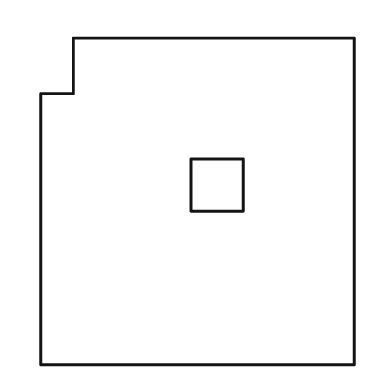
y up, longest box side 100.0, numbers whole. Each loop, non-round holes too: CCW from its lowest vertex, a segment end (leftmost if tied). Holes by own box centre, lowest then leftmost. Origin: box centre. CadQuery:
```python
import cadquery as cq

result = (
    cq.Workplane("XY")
    .moveTo(-48.0, -50.0)
    .lineTo(48.0, -50.0)
    .lineTo(48.0, 50.0)
    .lineTo(-38.0, 50.0)
    .lineTo(-38.0, 33.0)
    .lineTo(-48.0, 33.0)
    .close()
    .moveTo(-2.0, -3.0)
    .lineTo(14.0, -3.0)
    .lineTo(14.0, 13.0)
    .lineTo(-2.0, 13.0)
    .close()
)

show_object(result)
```